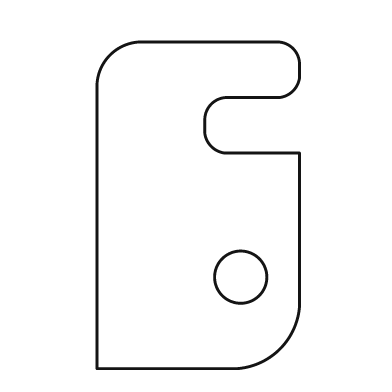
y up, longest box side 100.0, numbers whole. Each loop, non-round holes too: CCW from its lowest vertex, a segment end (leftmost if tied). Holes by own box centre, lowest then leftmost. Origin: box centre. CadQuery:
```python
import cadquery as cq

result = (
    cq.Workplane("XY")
    .moveTo(-31.0, -50.0)
    .lineTo(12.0, -50.0)
    .threePointArc((25.0, -44.0), (31.0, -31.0))
    .lineTo(31.0, 16.0)
    .lineTo(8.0, 16.0)
    .threePointArc((4.0, 18.0), (2.0, 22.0))
    .lineTo(2.0, 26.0)
    .threePointArc((4.0, 31.0), (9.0, 33.0))
    .lineTo(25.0, 33.0)
    .threePointArc((29.0, 35.0), (31.0, 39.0))
    .lineTo(31.0, 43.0)
    .threePointArc((29.0, 48.0), (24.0, 50.0))
    .lineTo(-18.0, 50.0)
    .threePointArc((-27.0, 46.0), (-31.0, 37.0))
    .close()
    .moveTo(13.0, -22.0)
    .circle(8.0)
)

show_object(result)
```